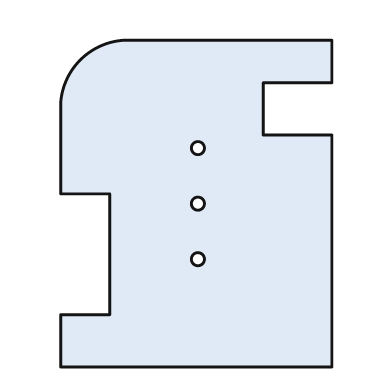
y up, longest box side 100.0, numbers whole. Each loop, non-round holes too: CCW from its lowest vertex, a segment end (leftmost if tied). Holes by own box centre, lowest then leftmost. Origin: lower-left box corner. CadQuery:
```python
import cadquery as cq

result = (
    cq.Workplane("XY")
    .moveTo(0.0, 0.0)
    .lineTo(83.0, 0.0)
    .lineTo(83.0, 71.0)
    .lineTo(62.0, 71.0)
    .lineTo(62.0, 87.0)
    .lineTo(83.0, 87.0)
    .lineTo(83.0, 100.0)
    .lineTo(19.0, 100.0)
    .threePointArc((6.0, 94.0), (0.0, 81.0))
    .lineTo(0.0, 53.0)
    .lineTo(15.0, 53.0)
    .lineTo(15.0, 16.0)
    .lineTo(0.0, 16.0)
    .close()
    .moveTo(42.0, 33.0)
    .circle(2.0)
    .moveTo(42.0, 50.0)
    .circle(2.0)
    .moveTo(42.0, 67.0)
    .circle(2.0)
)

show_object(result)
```